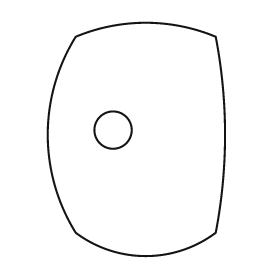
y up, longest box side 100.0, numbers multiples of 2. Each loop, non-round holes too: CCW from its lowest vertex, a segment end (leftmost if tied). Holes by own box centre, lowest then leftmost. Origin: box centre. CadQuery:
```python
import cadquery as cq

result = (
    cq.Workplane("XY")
    .moveTo(-26.0, -40.0)
    .threePointArc((4.0, -50.0), (34.0, -40.0))
    .threePointArc((38.0, 2.0), (34.0, 44.0))
    .threePointArc((4.0, 50.0), (-26.0, 44.0))
    .threePointArc((-38.0, 2.0), (-26.0, -40.0))
    .close()
    .moveTo(-10.0, 4.0)
    .circle(8.0)
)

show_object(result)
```